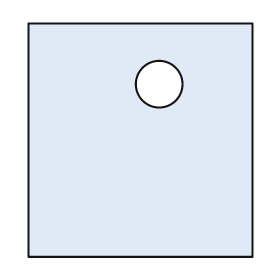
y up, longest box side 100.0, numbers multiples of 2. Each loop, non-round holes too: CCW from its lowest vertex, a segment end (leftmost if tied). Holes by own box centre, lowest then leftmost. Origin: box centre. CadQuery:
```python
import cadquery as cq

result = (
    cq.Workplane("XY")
    .moveTo(-48.0, -50.0)
    .lineTo(48.0, -50.0)
    .lineTo(48.0, 50.0)
    .lineTo(-48.0, 50.0)
    .close()
    .moveTo(8.0, 24.0)
    .circle(10.0)
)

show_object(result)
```